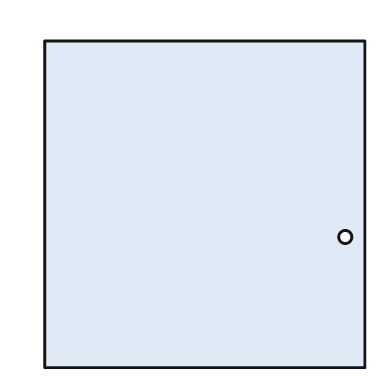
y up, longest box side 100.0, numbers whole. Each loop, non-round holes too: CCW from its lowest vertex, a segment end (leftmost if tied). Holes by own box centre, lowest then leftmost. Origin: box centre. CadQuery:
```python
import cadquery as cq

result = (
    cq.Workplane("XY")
    .moveTo(-49.0, -50.0)
    .lineTo(49.0, -50.0)
    .lineTo(49.0, 50.0)
    .lineTo(-49.0, 50.0)
    .close()
    .moveTo(43.0, -10.0)
    .circle(2.0)
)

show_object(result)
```